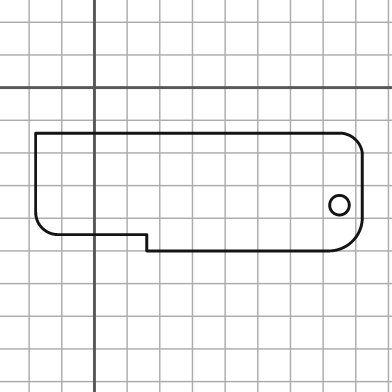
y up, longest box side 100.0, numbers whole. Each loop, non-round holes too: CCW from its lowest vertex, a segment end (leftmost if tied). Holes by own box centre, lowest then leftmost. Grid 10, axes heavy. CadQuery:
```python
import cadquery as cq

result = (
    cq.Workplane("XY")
    .moveTo(16.0, -50.0)
    .lineTo(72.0, -50.0)
    .threePointArc((79.0, -47.0), (82.0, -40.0))
    .lineTo(82.0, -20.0)
    .threePointArc((80.0, -16.0), (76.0, -14.0))
    .lineTo(-18.0, -14.0)
    .lineTo(-18.0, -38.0)
    .threePointArc((-16.0, -43.0), (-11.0, -45.0))
    .lineTo(16.0, -45.0)
    .close()
    .moveTo(75.0, -36.0)
    .circle(3.0)
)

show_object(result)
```